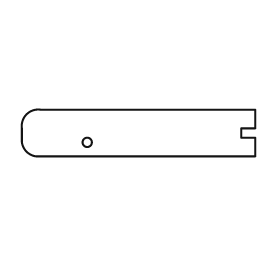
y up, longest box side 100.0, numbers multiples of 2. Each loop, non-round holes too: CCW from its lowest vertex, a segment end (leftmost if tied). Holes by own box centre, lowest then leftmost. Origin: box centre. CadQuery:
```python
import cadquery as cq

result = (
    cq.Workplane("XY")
    .moveTo(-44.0, -10.0)
    .lineTo(50.0, -10.0)
    .lineTo(50.0, -2.0)
    .lineTo(44.0, -2.0)
    .lineTo(44.0, 2.0)
    .lineTo(50.0, 2.0)
    .lineTo(50.0, 10.0)
    .lineTo(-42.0, 10.0)
    .threePointArc((-48.0, 8.0), (-50.0, 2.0))
    .lineTo(-50.0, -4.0)
    .threePointArc((-48.0, -8.0), (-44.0, -10.0))
    .close()
    .moveTo(-22.0, -4.0)
    .circle(2.0)
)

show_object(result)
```